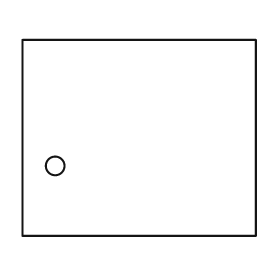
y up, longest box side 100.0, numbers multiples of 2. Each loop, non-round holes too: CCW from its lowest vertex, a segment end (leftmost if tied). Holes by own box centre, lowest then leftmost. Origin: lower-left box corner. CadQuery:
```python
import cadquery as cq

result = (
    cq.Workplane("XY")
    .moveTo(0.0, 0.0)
    .lineTo(100.0, 0.0)
    .lineTo(100.0, 84.0)
    .lineTo(0.0, 84.0)
    .close()
    .moveTo(14.0, 30.0)
    .circle(4.0)
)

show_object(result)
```